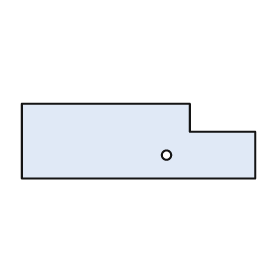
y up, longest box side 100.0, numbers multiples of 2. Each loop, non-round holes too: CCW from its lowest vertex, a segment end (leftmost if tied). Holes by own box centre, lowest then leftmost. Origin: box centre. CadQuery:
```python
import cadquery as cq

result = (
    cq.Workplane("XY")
    .moveTo(-50.0, -16.0)
    .lineTo(50.0, -16.0)
    .lineTo(50.0, 4.0)
    .lineTo(22.0, 4.0)
    .lineTo(22.0, 16.0)
    .lineTo(-50.0, 16.0)
    .close()
    .moveTo(12.0, -6.0)
    .circle(2.0)
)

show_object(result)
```